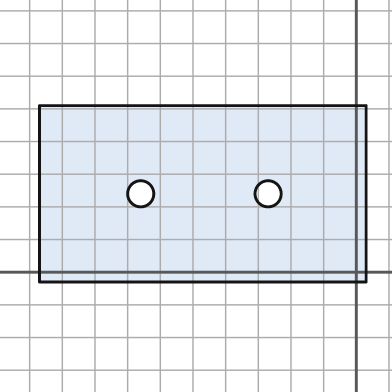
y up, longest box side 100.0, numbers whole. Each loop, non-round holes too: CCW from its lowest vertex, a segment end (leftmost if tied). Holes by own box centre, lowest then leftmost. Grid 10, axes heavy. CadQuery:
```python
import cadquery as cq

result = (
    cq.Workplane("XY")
    .moveTo(-97.0, -3.0)
    .lineTo(3.0, -3.0)
    .lineTo(3.0, 51.0)
    .lineTo(-97.0, 51.0)
    .close()
    .moveTo(-66.0, 24.0)
    .circle(4.0)
    .moveTo(-27.0, 24.0)
    .circle(4.0)
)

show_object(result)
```